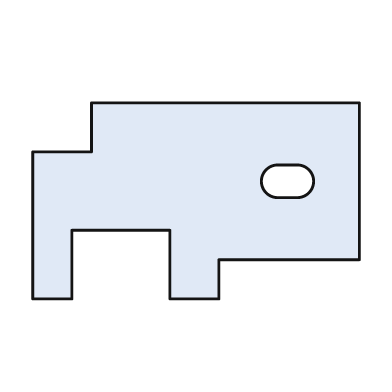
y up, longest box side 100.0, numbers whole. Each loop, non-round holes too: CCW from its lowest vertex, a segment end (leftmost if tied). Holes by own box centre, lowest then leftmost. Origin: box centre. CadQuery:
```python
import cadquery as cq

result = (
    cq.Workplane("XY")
    .moveTo(-50.0, -30.0)
    .lineTo(-38.0, -30.0)
    .lineTo(-38.0, -9.0)
    .lineTo(-8.0, -9.0)
    .lineTo(-8.0, -30.0)
    .lineTo(7.0, -30.0)
    .lineTo(7.0, -18.0)
    .lineTo(50.0, -18.0)
    .lineTo(50.0, 30.0)
    .lineTo(-32.0, 30.0)
    .lineTo(-32.0, 15.0)
    .lineTo(-50.0, 15.0)
    .close()
    .moveTo(25.0, 1.0)
    .lineTo(31.0, 1.0)
    .threePointArc((36.0, 6.0), (31.0, 11.0))
    .lineTo(25.0, 11.0)
    .threePointArc((20.0, 6.0), (25.0, 1.0))
    .close()
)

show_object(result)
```